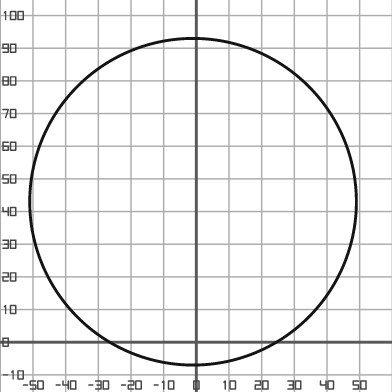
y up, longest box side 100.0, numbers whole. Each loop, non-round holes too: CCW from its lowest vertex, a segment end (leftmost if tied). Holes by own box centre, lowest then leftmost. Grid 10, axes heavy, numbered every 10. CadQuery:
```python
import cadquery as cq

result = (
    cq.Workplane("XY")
    .moveTo(-1.0, 43.0)
    .circle(50.0)
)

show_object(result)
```